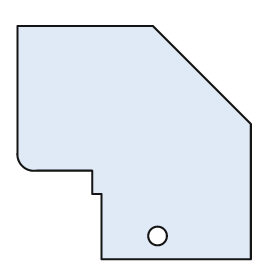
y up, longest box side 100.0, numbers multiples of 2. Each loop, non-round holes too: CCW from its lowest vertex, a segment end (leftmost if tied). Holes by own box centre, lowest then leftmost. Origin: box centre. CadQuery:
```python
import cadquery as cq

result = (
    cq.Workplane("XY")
    .moveTo(-14.0, -50.0)
    .lineTo(50.0, -50.0)
    .lineTo(50.0, 8.0)
    .lineTo(8.0, 50.0)
    .lineTo(-50.0, 50.0)
    .lineTo(-50.0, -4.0)
    .threePointArc((-48.0, -10.0), (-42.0, -12.0))
    .lineTo(-18.0, -12.0)
    .lineTo(-18.0, -22.0)
    .lineTo(-14.0, -22.0)
    .close()
    .moveTo(10.0, -40.0)
    .circle(4.0)
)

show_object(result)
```